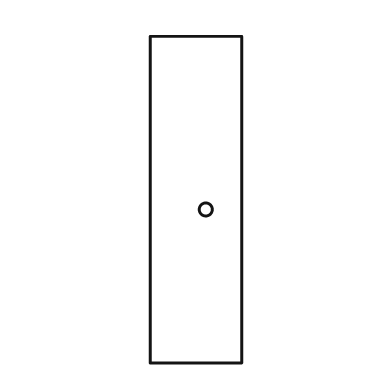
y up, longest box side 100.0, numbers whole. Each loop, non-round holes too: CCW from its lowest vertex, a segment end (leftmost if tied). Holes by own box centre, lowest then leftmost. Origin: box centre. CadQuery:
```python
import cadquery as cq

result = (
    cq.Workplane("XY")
    .moveTo(-14.0, -50.0)
    .lineTo(14.0, -50.0)
    .lineTo(14.0, 50.0)
    .lineTo(-14.0, 50.0)
    .close()
    .moveTo(3.0, -3.0)
    .circle(2.0)
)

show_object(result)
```